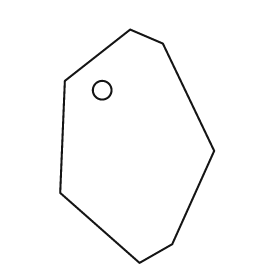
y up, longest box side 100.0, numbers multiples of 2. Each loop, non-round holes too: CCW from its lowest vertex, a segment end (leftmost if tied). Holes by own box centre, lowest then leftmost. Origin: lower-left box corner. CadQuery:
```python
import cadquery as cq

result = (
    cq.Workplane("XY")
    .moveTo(34.0, 0.0)
    .lineTo(48.0, 8.0)
    .lineTo(66.0, 48.0)
    .lineTo(44.0, 94.0)
    .lineTo(30.0, 100.0)
    .lineTo(2.0, 78.0)
    .lineTo(0.0, 30.0)
    .close()
    .moveTo(18.0, 74.0)
    .circle(4.0)
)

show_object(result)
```